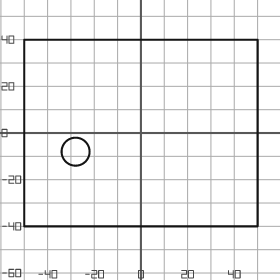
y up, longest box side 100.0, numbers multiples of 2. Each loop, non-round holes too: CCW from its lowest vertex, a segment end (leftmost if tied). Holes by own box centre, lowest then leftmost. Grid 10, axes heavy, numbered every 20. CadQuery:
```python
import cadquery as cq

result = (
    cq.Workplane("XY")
    .moveTo(-50.0, -40.0)
    .lineTo(50.0, -40.0)
    .lineTo(50.0, 40.0)
    .lineTo(-50.0, 40.0)
    .close()
    .moveTo(-28.0, -8.0)
    .circle(6.0)
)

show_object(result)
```